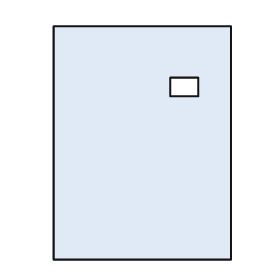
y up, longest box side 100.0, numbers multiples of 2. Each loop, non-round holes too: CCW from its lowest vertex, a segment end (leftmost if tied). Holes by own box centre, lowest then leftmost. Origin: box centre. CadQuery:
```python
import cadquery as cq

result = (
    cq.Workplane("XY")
    .moveTo(-38.0, -50.0)
    .lineTo(38.0, -50.0)
    .lineTo(38.0, 50.0)
    .lineTo(-38.0, 50.0)
    .close()
    .moveTo(12.0, 20.0)
    .lineTo(24.0, 20.0)
    .lineTo(24.0, 28.0)
    .lineTo(12.0, 28.0)
    .close()
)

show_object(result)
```